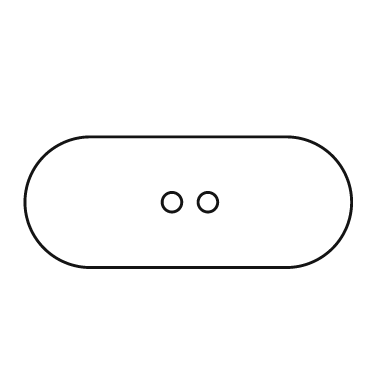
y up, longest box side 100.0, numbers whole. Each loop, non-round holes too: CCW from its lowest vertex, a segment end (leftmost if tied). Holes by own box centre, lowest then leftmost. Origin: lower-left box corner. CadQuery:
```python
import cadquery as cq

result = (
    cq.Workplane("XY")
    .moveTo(20.0, 0.0)
    .lineTo(80.0, 0.0)
    .threePointArc((100.0, 20.0), (80.0, 40.0))
    .lineTo(20.0, 40.0)
    .threePointArc((0.0, 20.0), (20.0, 0.0))
    .close()
    .moveTo(45.0, 20.0)
    .circle(3.0)
    .moveTo(56.0, 20.0)
    .circle(3.0)
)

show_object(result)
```